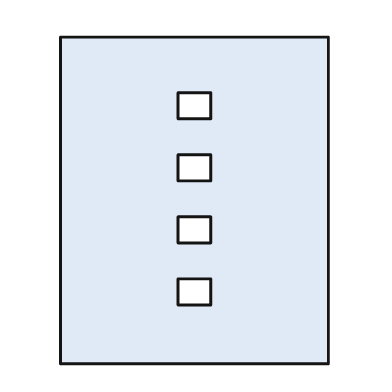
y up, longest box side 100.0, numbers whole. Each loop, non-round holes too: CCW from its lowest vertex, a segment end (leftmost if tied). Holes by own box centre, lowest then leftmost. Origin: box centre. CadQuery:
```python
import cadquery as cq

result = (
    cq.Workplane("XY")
    .moveTo(-41.0, -50.0)
    .lineTo(41.0, -50.0)
    .lineTo(41.0, 50.0)
    .lineTo(-41.0, 50.0)
    .close()
    .moveTo(-5.0, -32.0)
    .lineTo(5.0, -32.0)
    .lineTo(5.0, -24.0)
    .lineTo(-5.0, -24.0)
    .close()
    .moveTo(-5.0, -13.0)
    .lineTo(5.0, -13.0)
    .lineTo(5.0, -5.0)
    .lineTo(-5.0, -5.0)
    .close()
    .moveTo(-5.0, 6.0)
    .lineTo(5.0, 6.0)
    .lineTo(5.0, 14.0)
    .lineTo(-5.0, 14.0)
    .close()
    .moveTo(-5.0, 25.0)
    .lineTo(5.0, 25.0)
    .lineTo(5.0, 33.0)
    .lineTo(-5.0, 33.0)
    .close()
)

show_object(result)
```